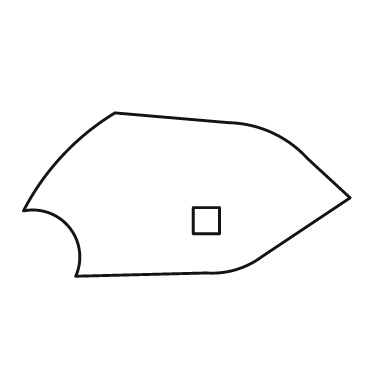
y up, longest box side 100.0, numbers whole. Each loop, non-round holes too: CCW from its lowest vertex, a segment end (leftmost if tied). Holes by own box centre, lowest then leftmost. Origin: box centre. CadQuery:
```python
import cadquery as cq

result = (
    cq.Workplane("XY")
    .moveTo(-34.0, -25.0)
    .lineTo(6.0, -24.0)
    .threePointArc((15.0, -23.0), (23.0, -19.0))
    .lineTo(50.0, -1.0)
    .lineTo(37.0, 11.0)
    .threePointArc((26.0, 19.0), (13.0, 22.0))
    .lineTo(-22.0, 25.0)
    .threePointArc((-38.0, 12.0), (-50.0, -5.0))
    .threePointArc((-36.0, -10.0), (-34.0, -25.0))
    .close()
    .moveTo(2.0, -12.0)
    .lineTo(10.0, -12.0)
    .lineTo(10.0, -4.0)
    .lineTo(2.0, -4.0)
    .close()
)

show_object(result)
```